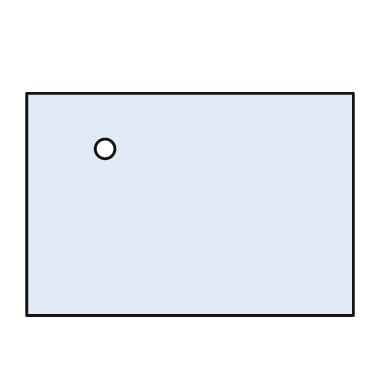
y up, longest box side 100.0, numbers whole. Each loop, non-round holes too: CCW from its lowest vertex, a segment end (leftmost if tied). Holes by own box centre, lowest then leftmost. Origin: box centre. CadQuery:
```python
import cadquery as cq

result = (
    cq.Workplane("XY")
    .moveTo(-50.0, -34.0)
    .lineTo(50.0, -34.0)
    .lineTo(50.0, 34.0)
    .lineTo(-50.0, 34.0)
    .close()
    .moveTo(-26.0, 17.0)
    .circle(3.0)
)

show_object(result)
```